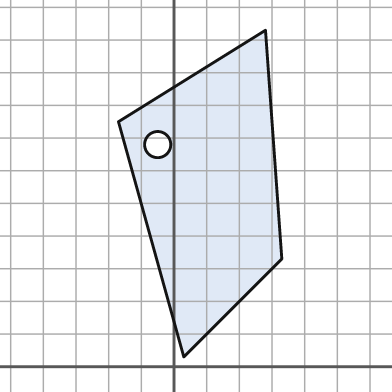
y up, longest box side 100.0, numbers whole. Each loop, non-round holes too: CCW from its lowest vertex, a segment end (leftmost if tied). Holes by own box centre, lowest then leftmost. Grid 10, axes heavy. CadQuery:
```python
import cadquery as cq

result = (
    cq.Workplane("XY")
    .moveTo(3.0, 3.0)
    .lineTo(33.0, 33.0)
    .lineTo(28.0, 103.0)
    .lineTo(-17.0, 75.0)
    .close()
    .moveTo(-5.0, 68.0)
    .circle(4.0)
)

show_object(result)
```